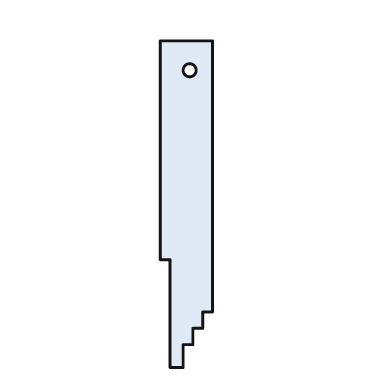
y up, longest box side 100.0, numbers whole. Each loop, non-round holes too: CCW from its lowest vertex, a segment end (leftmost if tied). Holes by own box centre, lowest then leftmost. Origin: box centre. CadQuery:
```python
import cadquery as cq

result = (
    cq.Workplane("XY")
    .moveTo(-5.0, -50.0)
    .lineTo(-1.0, -50.0)
    .lineTo(-1.0, -43.0)
    .lineTo(2.0, -43.0)
    .lineTo(2.0, -38.0)
    .lineTo(5.0, -38.0)
    .lineTo(5.0, -33.0)
    .lineTo(8.0, -33.0)
    .lineTo(8.0, 50.0)
    .lineTo(-8.0, 50.0)
    .lineTo(-8.0, -17.0)
    .lineTo(-5.0, -17.0)
    .close()
    .moveTo(1.0, 41.0)
    .circle(2.0)
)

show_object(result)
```